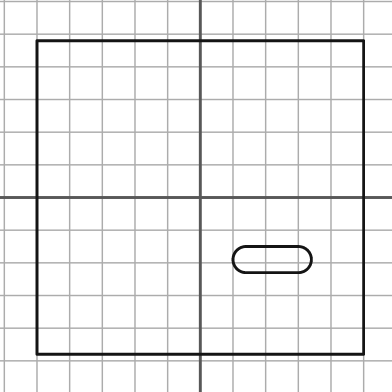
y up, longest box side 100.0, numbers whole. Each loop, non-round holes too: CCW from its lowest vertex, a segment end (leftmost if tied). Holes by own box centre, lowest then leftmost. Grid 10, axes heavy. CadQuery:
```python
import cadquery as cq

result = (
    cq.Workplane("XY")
    .moveTo(-50.0, -48.0)
    .lineTo(50.0, -48.0)
    .lineTo(50.0, 48.0)
    .lineTo(-50.0, 48.0)
    .close()
    .moveTo(14.0, -23.0)
    .lineTo(30.0, -23.0)
    .threePointArc((34.0, -19.0), (30.0, -15.0))
    .lineTo(14.0, -15.0)
    .threePointArc((10.0, -19.0), (14.0, -23.0))
    .close()
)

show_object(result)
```